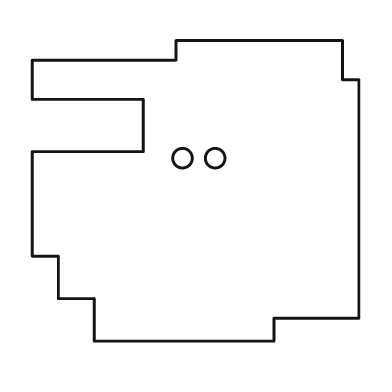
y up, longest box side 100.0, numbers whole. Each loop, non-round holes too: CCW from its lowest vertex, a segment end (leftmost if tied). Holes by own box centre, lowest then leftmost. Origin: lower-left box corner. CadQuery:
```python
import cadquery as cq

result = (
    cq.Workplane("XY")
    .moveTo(19.0, 0.0)
    .lineTo(74.0, 0.0)
    .lineTo(74.0, 7.0)
    .lineTo(100.0, 7.0)
    .lineTo(100.0, 80.0)
    .lineTo(95.0, 80.0)
    .lineTo(95.0, 92.0)
    .lineTo(44.0, 92.0)
    .lineTo(44.0, 86.0)
    .lineTo(0.0, 86.0)
    .lineTo(0.0, 74.0)
    .lineTo(34.0, 74.0)
    .lineTo(34.0, 58.0)
    .lineTo(0.0, 58.0)
    .lineTo(0.0, 26.0)
    .lineTo(8.0, 26.0)
    .lineTo(8.0, 13.0)
    .lineTo(19.0, 13.0)
    .close()
    .moveTo(46.0, 56.0)
    .circle(3.0)
    .moveTo(56.0, 56.0)
    .circle(3.0)
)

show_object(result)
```